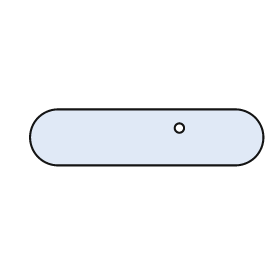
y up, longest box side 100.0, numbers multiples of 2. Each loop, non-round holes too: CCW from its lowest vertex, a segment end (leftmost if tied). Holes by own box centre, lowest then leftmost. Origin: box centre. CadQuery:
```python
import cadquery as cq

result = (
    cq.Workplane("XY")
    .moveTo(-38.0, -12.0)
    .lineTo(38.0, -12.0)
    .threePointArc((50.0, 0.0), (38.0, 12.0))
    .lineTo(-38.0, 12.0)
    .threePointArc((-50.0, 0.0), (-38.0, -12.0))
    .close()
    .moveTo(14.0, 4.0)
    .circle(2.0)
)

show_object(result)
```